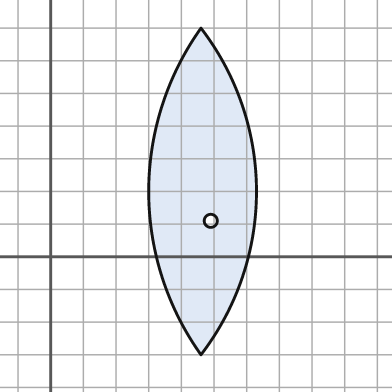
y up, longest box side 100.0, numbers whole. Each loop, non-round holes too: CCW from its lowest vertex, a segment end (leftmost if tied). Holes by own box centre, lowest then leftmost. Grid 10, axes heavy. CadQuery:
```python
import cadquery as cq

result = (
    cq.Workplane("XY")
    .moveTo(46.0, -30.0)
    .threePointArc((63.0, 20.0), (46.0, 70.0))
    .threePointArc((30.0, 20.0), (46.0, -30.0))
    .close()
    .moveTo(49.0, 11.0)
    .circle(2.0)
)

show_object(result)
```